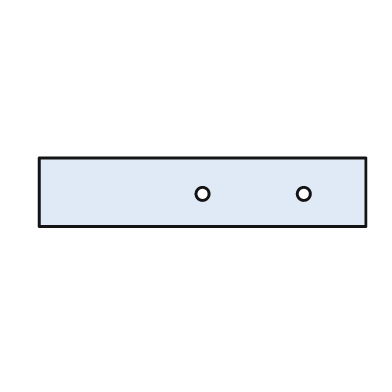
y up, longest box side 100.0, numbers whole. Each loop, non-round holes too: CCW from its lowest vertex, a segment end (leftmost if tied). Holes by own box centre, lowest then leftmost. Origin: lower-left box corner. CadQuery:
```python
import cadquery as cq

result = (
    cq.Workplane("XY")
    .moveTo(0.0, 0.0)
    .lineTo(100.0, 0.0)
    .lineTo(100.0, 21.0)
    .lineTo(0.0, 21.0)
    .close()
    .moveTo(50.0, 10.0)
    .circle(2.0)
    .moveTo(81.0, 10.0)
    .circle(2.0)
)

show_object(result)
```